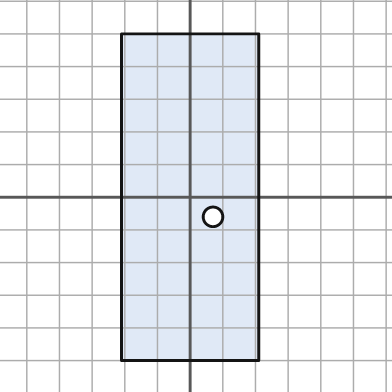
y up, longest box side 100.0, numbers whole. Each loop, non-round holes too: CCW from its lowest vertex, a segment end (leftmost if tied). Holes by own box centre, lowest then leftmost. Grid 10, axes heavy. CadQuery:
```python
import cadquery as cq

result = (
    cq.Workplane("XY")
    .moveTo(-21.0, -50.0)
    .lineTo(21.0, -50.0)
    .lineTo(21.0, 50.0)
    .lineTo(-21.0, 50.0)
    .close()
    .moveTo(7.0, -6.0)
    .circle(3.0)
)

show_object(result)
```